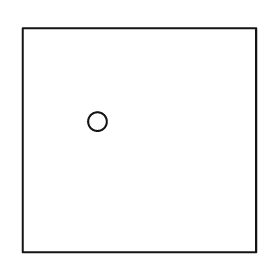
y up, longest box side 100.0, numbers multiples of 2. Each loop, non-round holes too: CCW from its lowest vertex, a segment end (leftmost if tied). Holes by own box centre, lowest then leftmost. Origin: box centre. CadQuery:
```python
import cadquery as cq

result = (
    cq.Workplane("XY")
    .moveTo(-50.0, -48.0)
    .lineTo(50.0, -48.0)
    .lineTo(50.0, 48.0)
    .lineTo(-50.0, 48.0)
    .close()
    .moveTo(-18.0, 8.0)
    .circle(4.0)
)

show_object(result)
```